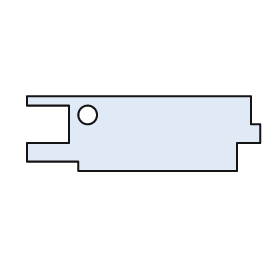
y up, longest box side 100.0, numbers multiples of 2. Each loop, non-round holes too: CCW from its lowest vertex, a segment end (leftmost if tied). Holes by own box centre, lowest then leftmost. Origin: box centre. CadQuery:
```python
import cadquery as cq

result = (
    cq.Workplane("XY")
    .moveTo(-28.0, -16.0)
    .lineTo(40.0, -16.0)
    .lineTo(40.0, -4.0)
    .lineTo(50.0, -4.0)
    .lineTo(50.0, 4.0)
    .lineTo(46.0, 4.0)
    .lineTo(46.0, 16.0)
    .lineTo(-50.0, 16.0)
    .lineTo(-50.0, 12.0)
    .lineTo(-32.0, 12.0)
    .lineTo(-32.0, -4.0)
    .lineTo(-50.0, -4.0)
    .lineTo(-50.0, -12.0)
    .lineTo(-28.0, -12.0)
    .close()
    .moveTo(-24.0, 8.0)
    .circle(4.0)
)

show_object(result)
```